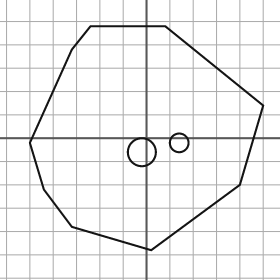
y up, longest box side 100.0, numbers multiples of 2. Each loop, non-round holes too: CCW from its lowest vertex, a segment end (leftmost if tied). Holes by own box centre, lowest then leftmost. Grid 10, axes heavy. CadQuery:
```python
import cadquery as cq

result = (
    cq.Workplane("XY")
    .moveTo(2.0, -48.0)
    .lineTo(40.0, -20.0)
    .lineTo(50.0, 14.0)
    .lineTo(8.0, 48.0)
    .lineTo(-24.0, 48.0)
    .lineTo(-32.0, 38.0)
    .lineTo(-50.0, -2.0)
    .lineTo(-44.0, -22.0)
    .lineTo(-32.0, -38.0)
    .close()
    .moveTo(-2.0, -6.0)
    .circle(6.0)
    .moveTo(14.0, -2.0)
    .circle(4.0)
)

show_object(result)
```